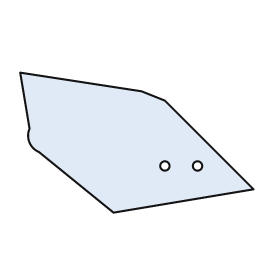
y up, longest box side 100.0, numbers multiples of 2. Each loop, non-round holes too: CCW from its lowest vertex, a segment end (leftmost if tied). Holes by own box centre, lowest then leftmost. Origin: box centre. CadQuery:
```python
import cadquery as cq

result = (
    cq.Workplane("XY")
    .moveTo(-10.0, -30.0)
    .lineTo(50.0, -20.0)
    .lineTo(12.0, 18.0)
    .lineTo(2.0, 22.0)
    .lineTo(-50.0, 30.0)
    .lineTo(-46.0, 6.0)
    .threePointArc((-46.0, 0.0), (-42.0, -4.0))
    .close()
    .moveTo(12.0, -10.0)
    .circle(2.0)
    .moveTo(26.0, -10.0)
    .circle(2.0)
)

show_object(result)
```